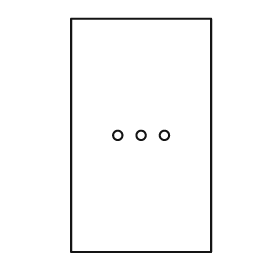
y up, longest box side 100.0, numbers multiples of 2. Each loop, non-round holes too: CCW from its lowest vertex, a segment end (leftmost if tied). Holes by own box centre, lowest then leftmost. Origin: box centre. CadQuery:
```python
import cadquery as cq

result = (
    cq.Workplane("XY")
    .moveTo(-30.0, -50.0)
    .lineTo(30.0, -50.0)
    .lineTo(30.0, 50.0)
    .lineTo(-30.0, 50.0)
    .close()
    .moveTo(-10.0, 0.0)
    .circle(2.0)
    .moveTo(0.0, 0.0)
    .circle(2.0)
    .moveTo(10.0, 0.0)
    .circle(2.0)
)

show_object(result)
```